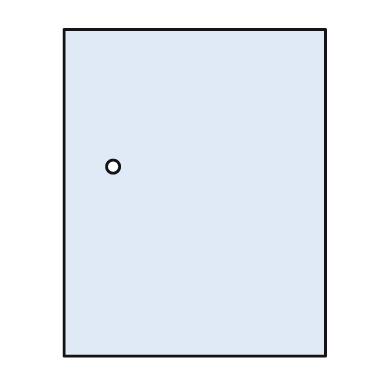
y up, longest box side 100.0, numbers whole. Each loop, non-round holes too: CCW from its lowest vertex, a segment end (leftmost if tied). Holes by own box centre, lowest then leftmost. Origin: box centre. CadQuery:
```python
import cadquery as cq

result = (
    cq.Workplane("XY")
    .moveTo(-40.0, -50.0)
    .lineTo(40.0, -50.0)
    .lineTo(40.0, 50.0)
    .lineTo(-40.0, 50.0)
    .close()
    .moveTo(-25.0, 8.0)
    .circle(2.0)
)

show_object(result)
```